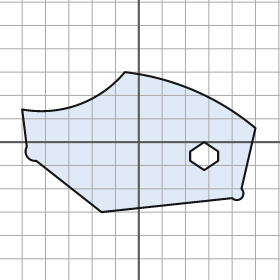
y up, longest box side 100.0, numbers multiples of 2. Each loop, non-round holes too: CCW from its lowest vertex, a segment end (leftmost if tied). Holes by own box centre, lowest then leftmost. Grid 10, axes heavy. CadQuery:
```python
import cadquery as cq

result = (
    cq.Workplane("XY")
    .moveTo(-16.0, -30.0)
    .lineTo(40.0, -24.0)
    .threePointArc((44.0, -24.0), (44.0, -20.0))
    .lineTo(50.0, 6.0)
    .threePointArc((24.0, 22.0), (-6.0, 30.0))
    .threePointArc((-26.0, 16.0), (-50.0, 14.0))
    .lineTo(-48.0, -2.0)
    .threePointArc((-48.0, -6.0), (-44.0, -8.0))
    .close()
    .moveTo(28.0, -12.0)
    .lineTo(34.0, -8.0)
    .lineTo(34.0, -4.0)
    .lineTo(28.0, 0.0)
    .lineTo(22.0, -4.0)
    .lineTo(22.0, -8.0)
    .close()
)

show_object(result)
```